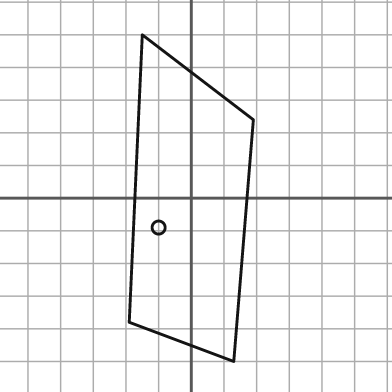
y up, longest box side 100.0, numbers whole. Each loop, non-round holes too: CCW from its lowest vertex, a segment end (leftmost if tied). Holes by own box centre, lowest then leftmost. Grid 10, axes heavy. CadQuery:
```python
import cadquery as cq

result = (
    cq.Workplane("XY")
    .moveTo(13.0, -50.0)
    .lineTo(19.0, 24.0)
    .lineTo(-15.0, 50.0)
    .lineTo(-19.0, -38.0)
    .close()
    .moveTo(-10.0, -9.0)
    .circle(2.0)
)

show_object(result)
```